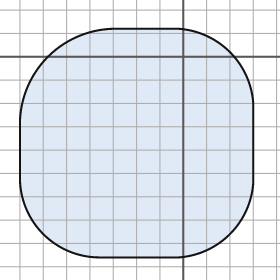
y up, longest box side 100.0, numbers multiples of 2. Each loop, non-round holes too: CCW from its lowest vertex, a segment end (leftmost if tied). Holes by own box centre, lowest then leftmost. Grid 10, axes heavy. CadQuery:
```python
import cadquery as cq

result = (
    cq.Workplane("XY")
    .moveTo(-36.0, -86.0)
    .lineTo(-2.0, -86.0)
    .threePointArc((20.0, -76.0), (30.0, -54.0))
    .lineTo(30.0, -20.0)
    .threePointArc((20.0, 2.0), (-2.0, 12.0))
    .lineTo(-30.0, 12.0)
    .threePointArc((-58.0, 0.0), (-70.0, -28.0))
    .lineTo(-70.0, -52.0)
    .threePointArc((-60.0, -76.0), (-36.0, -86.0))
    .close()
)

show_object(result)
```